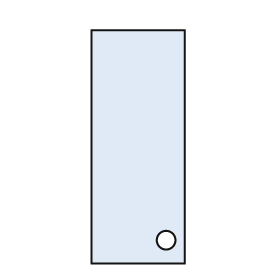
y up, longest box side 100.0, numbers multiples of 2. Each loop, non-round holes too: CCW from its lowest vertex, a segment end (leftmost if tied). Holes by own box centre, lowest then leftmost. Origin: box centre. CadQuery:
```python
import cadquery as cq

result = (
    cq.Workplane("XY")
    .moveTo(-20.0, -50.0)
    .lineTo(20.0, -50.0)
    .lineTo(20.0, 50.0)
    .lineTo(-20.0, 50.0)
    .close()
    .moveTo(12.0, -40.0)
    .circle(4.0)
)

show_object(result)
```